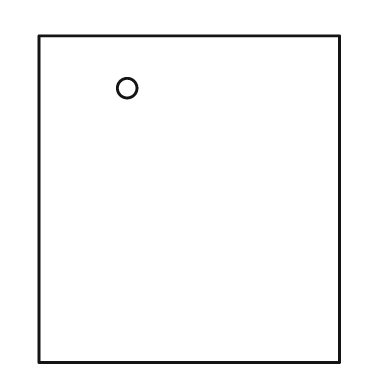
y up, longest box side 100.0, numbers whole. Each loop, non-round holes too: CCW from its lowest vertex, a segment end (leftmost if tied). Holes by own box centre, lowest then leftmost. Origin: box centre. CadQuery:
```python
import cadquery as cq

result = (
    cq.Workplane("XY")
    .moveTo(-46.0, -50.0)
    .lineTo(46.0, -50.0)
    .lineTo(46.0, 50.0)
    .lineTo(-46.0, 50.0)
    .close()
    .moveTo(-19.0, 34.0)
    .circle(3.0)
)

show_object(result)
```